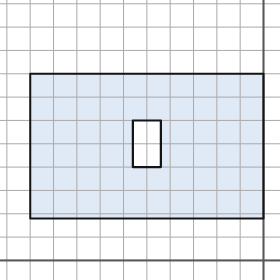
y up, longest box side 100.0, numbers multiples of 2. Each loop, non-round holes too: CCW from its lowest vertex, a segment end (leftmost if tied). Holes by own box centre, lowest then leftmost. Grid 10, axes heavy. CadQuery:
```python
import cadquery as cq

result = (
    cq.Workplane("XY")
    .moveTo(-100.0, 18.0)
    .lineTo(0.0, 18.0)
    .lineTo(0.0, 80.0)
    .lineTo(-100.0, 80.0)
    .close()
    .moveTo(-56.0, 40.0)
    .lineTo(-44.0, 40.0)
    .lineTo(-44.0, 60.0)
    .lineTo(-56.0, 60.0)
    .close()
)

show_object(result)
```